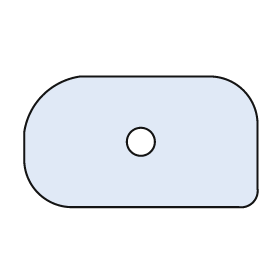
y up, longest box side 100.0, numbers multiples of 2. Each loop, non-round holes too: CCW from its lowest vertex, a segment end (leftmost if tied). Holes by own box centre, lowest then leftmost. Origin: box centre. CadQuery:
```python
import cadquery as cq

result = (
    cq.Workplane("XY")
    .moveTo(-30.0, -28.0)
    .lineTo(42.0, -28.0)
    .threePointArc((48.0, -26.0), (50.0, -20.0))
    .lineTo(50.0, 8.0)
    .threePointArc((44.0, 22.0), (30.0, 28.0))
    .lineTo(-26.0, 28.0)
    .threePointArc((-42.0, 20.0), (-50.0, 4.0))
    .lineTo(-50.0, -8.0)
    .threePointArc((-44.0, -22.0), (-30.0, -28.0))
    .close()
    .moveTo(0.0, 0.0)
    .circle(6.0)
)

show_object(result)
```